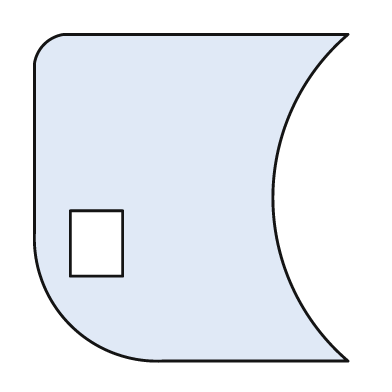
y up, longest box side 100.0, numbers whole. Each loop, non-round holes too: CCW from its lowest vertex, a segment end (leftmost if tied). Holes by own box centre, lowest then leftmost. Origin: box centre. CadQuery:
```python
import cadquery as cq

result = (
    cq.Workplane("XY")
    .moveTo(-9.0, -50.0)
    .lineTo(48.0, -50.0)
    .threePointArc((25.0, 0.0), (48.0, 50.0))
    .lineTo(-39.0, 50.0)
    .threePointArc((-45.0, 47.0), (-48.0, 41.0))
    .lineTo(-48.0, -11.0)
    .threePointArc((-37.0, -39.0), (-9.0, -50.0))
    .close()
    .moveTo(-37.0, -24.0)
    .lineTo(-21.0, -24.0)
    .lineTo(-21.0, -4.0)
    .lineTo(-37.0, -4.0)
    .close()
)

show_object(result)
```